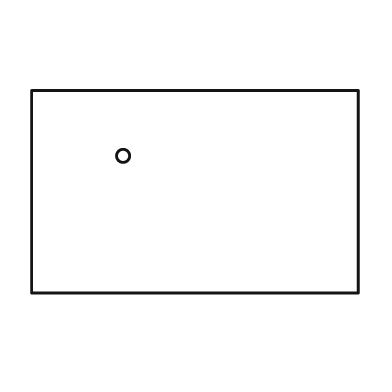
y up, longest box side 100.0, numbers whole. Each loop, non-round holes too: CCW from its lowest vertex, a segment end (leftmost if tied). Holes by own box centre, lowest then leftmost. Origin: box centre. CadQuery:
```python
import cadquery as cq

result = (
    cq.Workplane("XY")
    .moveTo(-50.0, -31.0)
    .lineTo(50.0, -31.0)
    .lineTo(50.0, 31.0)
    .lineTo(-50.0, 31.0)
    .close()
    .moveTo(-22.0, 11.0)
    .circle(2.0)
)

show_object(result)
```